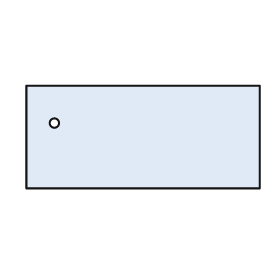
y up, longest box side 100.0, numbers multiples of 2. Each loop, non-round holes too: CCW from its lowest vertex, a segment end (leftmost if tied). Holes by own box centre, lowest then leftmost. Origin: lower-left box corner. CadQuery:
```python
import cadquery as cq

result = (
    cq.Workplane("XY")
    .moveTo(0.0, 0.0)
    .lineTo(100.0, 0.0)
    .lineTo(100.0, 44.0)
    .lineTo(0.0, 44.0)
    .close()
    .moveTo(12.0, 28.0)
    .circle(2.0)
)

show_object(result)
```